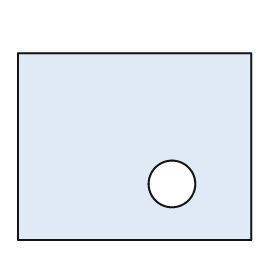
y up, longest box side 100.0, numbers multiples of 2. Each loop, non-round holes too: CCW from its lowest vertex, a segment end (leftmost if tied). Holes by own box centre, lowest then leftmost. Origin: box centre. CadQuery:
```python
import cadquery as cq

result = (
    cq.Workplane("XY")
    .moveTo(-50.0, -40.0)
    .lineTo(50.0, -40.0)
    .lineTo(50.0, 40.0)
    .lineTo(-50.0, 40.0)
    .close()
    .moveTo(16.0, -16.0)
    .circle(10.0)
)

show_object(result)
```